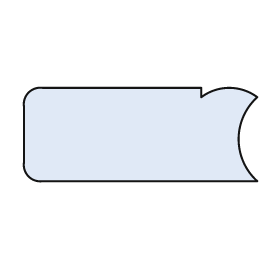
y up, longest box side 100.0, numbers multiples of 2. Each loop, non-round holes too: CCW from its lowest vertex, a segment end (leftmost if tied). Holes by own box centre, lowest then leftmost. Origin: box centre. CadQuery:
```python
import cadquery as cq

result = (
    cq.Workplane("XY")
    .moveTo(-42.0, -20.0)
    .lineTo(50.0, -20.0)
    .threePointArc((42.0, -2.0), (50.0, 16.0))
    .threePointArc((38.0, 20.0), (26.0, 16.0))
    .lineTo(26.0, 20.0)
    .lineTo(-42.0, 20.0)
    .threePointArc((-48.0, 18.0), (-50.0, 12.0))
    .lineTo(-50.0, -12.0)
    .threePointArc((-48.0, -18.0), (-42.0, -20.0))
    .close()
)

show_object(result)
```